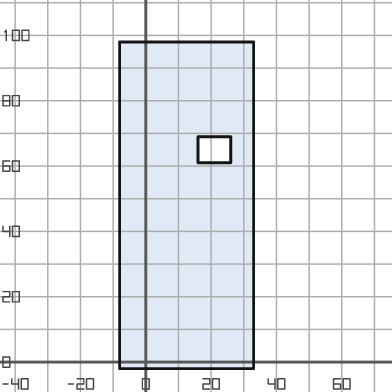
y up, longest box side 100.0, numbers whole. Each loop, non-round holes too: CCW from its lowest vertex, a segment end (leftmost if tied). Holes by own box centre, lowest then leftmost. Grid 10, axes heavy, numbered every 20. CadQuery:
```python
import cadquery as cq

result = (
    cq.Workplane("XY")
    .moveTo(-8.0, -2.0)
    .lineTo(33.0, -2.0)
    .lineTo(33.0, 98.0)
    .lineTo(-8.0, 98.0)
    .close()
    .moveTo(16.0, 61.0)
    .lineTo(26.0, 61.0)
    .lineTo(26.0, 69.0)
    .lineTo(16.0, 69.0)
    .close()
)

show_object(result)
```